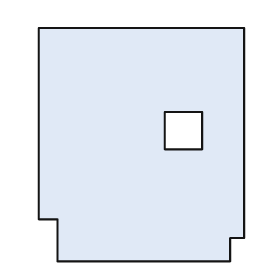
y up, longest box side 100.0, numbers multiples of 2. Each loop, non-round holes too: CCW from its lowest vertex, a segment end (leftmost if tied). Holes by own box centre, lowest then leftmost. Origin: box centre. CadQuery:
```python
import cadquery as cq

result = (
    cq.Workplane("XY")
    .moveTo(-36.0, -50.0)
    .lineTo(38.0, -50.0)
    .lineTo(38.0, -40.0)
    .lineTo(44.0, -40.0)
    .lineTo(44.0, 50.0)
    .lineTo(-44.0, 50.0)
    .lineTo(-44.0, -32.0)
    .lineTo(-36.0, -32.0)
    .close()
    .moveTo(10.0, -2.0)
    .lineTo(26.0, -2.0)
    .lineTo(26.0, 14.0)
    .lineTo(10.0, 14.0)
    .close()
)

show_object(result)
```